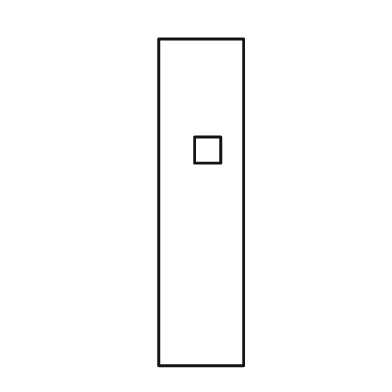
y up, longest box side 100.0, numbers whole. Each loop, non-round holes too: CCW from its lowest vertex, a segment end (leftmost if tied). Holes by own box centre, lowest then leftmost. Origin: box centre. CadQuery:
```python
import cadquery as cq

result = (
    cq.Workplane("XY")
    .moveTo(-13.0, -50.0)
    .lineTo(13.0, -50.0)
    .lineTo(13.0, 50.0)
    .lineTo(-13.0, 50.0)
    .close()
    .moveTo(-2.0, 12.0)
    .lineTo(6.0, 12.0)
    .lineTo(6.0, 20.0)
    .lineTo(-2.0, 20.0)
    .close()
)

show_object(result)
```